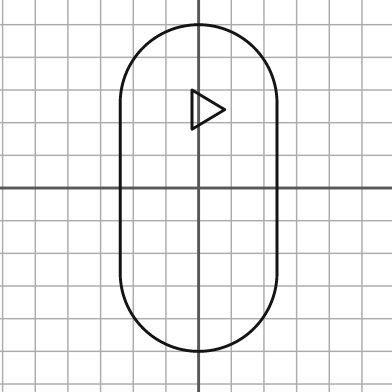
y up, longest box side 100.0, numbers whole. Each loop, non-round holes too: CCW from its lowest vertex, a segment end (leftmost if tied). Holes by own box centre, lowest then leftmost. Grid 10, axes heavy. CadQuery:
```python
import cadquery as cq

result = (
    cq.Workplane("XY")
    .moveTo(-24.0, -26.0)
    .threePointArc((0.0, -50.0), (24.0, -26.0))
    .lineTo(24.0, 26.0)
    .threePointArc((0.0, 50.0), (-24.0, 26.0))
    .close()
    .moveTo(-2.0, 18.0)
    .lineTo(8.0, 24.0)
    .lineTo(-2.0, 30.0)
    .close()
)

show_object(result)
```